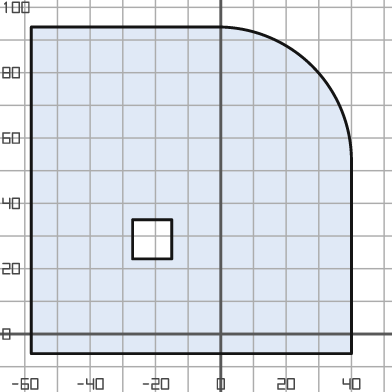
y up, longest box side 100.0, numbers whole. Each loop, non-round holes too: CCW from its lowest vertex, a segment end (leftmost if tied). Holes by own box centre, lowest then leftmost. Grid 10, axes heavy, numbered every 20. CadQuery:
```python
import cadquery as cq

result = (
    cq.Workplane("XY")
    .moveTo(-58.0, -6.0)
    .lineTo(40.0, -6.0)
    .lineTo(40.0, 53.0)
    .threePointArc((28.0, 82.0), (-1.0, 94.0))
    .lineTo(-58.0, 94.0)
    .close()
    .moveTo(-27.0, 23.0)
    .lineTo(-15.0, 23.0)
    .lineTo(-15.0, 35.0)
    .lineTo(-27.0, 35.0)
    .close()
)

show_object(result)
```